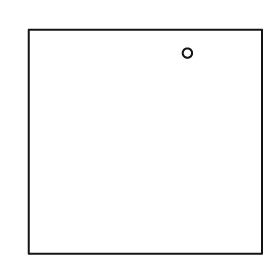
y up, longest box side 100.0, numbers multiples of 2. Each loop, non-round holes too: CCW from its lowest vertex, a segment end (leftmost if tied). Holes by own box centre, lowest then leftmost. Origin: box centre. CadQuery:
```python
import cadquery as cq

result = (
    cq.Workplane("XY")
    .moveTo(-50.0, -48.0)
    .lineTo(50.0, -48.0)
    .lineTo(50.0, 48.0)
    .lineTo(-50.0, 48.0)
    .close()
    .moveTo(18.0, 38.0)
    .circle(2.0)
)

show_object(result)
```